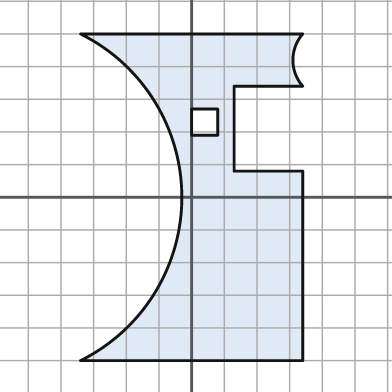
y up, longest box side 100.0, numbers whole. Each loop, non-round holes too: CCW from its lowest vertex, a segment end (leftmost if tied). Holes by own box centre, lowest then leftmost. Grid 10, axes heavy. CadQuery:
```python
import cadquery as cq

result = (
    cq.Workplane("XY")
    .moveTo(-34.0, -50.0)
    .lineTo(34.0, -50.0)
    .lineTo(34.0, 8.0)
    .lineTo(13.0, 8.0)
    .lineTo(13.0, 34.0)
    .lineTo(34.0, 34.0)
    .threePointArc((31.0, 42.0), (34.0, 50.0))
    .lineTo(-34.0, 50.0)
    .threePointArc((-3.0, 0.0), (-34.0, -50.0))
    .close()
    .moveTo(0.0, 19.0)
    .lineTo(8.0, 19.0)
    .lineTo(8.0, 27.0)
    .lineTo(0.0, 27.0)
    .close()
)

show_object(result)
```